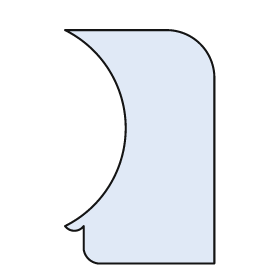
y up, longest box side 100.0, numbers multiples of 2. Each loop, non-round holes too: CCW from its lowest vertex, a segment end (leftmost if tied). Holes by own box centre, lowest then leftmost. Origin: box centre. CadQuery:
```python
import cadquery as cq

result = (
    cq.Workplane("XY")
    .moveTo(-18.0, -50.0)
    .lineTo(32.0, -50.0)
    .lineTo(32.0, 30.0)
    .threePointArc((26.0, 44.0), (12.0, 50.0))
    .lineTo(-32.0, 50.0)
    .threePointArc((-6.0, 8.0), (-32.0, -34.0))
    .threePointArc((-28.0, -36.0), (-24.0, -34.0))
    .lineTo(-24.0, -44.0)
    .threePointArc((-22.0, -48.0), (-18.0, -50.0))
    .close()
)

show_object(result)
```